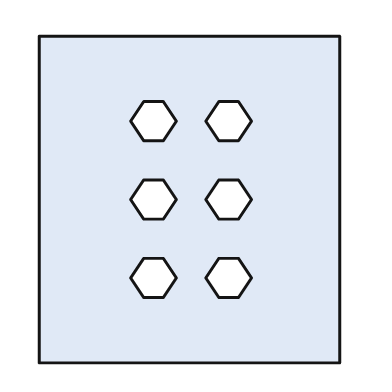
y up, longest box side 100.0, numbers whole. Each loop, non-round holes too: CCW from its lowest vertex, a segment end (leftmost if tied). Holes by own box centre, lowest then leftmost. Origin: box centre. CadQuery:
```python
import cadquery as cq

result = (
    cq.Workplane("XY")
    .moveTo(-46.0, -50.0)
    .lineTo(46.0, -50.0)
    .lineTo(46.0, 50.0)
    .lineTo(-46.0, 50.0)
    .close()
    .moveTo(-14.0, -30.0)
    .lineTo(-8.0, -30.0)
    .lineTo(-4.0, -24.0)
    .lineTo(-8.0, -18.0)
    .lineTo(-14.0, -18.0)
    .lineTo(-18.0, -24.0)
    .close()
    .moveTo(9.0, -30.0)
    .lineTo(15.0, -30.0)
    .lineTo(19.0, -24.0)
    .lineTo(15.0, -18.0)
    .lineTo(9.0, -18.0)
    .lineTo(5.0, -24.0)
    .close()
    .moveTo(-14.0, -6.0)
    .lineTo(-8.0, -6.0)
    .lineTo(-4.0, 0.0)
    .lineTo(-8.0, 6.0)
    .lineTo(-14.0, 6.0)
    .lineTo(-18.0, 0.0)
    .close()
    .moveTo(9.0, -6.0)
    .lineTo(15.0, -6.0)
    .lineTo(19.0, 0.0)
    .lineTo(15.0, 6.0)
    .lineTo(9.0, 6.0)
    .lineTo(5.0, 0.0)
    .close()
    .moveTo(-14.0, 18.0)
    .lineTo(-8.0, 18.0)
    .lineTo(-4.0, 24.0)
    .lineTo(-8.0, 30.0)
    .lineTo(-14.0, 30.0)
    .lineTo(-18.0, 24.0)
    .close()
    .moveTo(9.0, 18.0)
    .lineTo(15.0, 18.0)
    .lineTo(19.0, 24.0)
    .lineTo(15.0, 30.0)
    .lineTo(9.0, 30.0)
    .lineTo(5.0, 24.0)
    .close()
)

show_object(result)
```